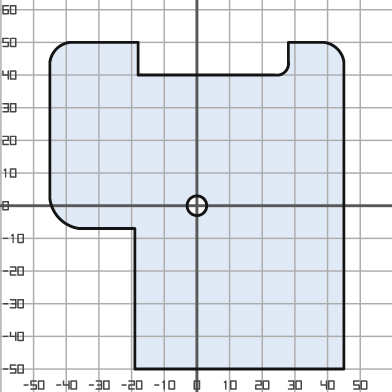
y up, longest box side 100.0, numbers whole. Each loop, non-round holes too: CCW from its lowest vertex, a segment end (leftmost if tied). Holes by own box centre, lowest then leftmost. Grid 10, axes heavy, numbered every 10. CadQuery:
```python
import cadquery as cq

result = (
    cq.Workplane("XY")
    .moveTo(-19.0, -50.0)
    .lineTo(45.0, -50.0)
    .lineTo(45.0, 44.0)
    .threePointArc((43.0, 48.0), (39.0, 50.0))
    .lineTo(28.0, 50.0)
    .lineTo(28.0, 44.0)
    .threePointArc((27.0, 41.0), (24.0, 40.0))
    .lineTo(-18.0, 40.0)
    .lineTo(-18.0, 50.0)
    .lineTo(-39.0, 50.0)
    .threePointArc((-43.0, 48.0), (-45.0, 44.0))
    .lineTo(-45.0, 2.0)
    .threePointArc((-42.0, -4.0), (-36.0, -7.0))
    .lineTo(-19.0, -7.0)
    .close()
    .moveTo(0.0, 0.0)
    .circle(3.0)
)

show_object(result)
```